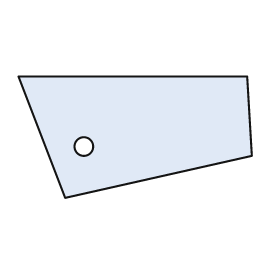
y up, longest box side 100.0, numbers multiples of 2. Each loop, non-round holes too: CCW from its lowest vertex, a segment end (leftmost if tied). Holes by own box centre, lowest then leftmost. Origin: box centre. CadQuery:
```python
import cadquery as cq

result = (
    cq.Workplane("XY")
    .moveTo(-30.0, -26.0)
    .lineTo(50.0, -8.0)
    .lineTo(48.0, 26.0)
    .lineTo(-50.0, 26.0)
    .close()
    .moveTo(-22.0, -4.0)
    .circle(4.0)
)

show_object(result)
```